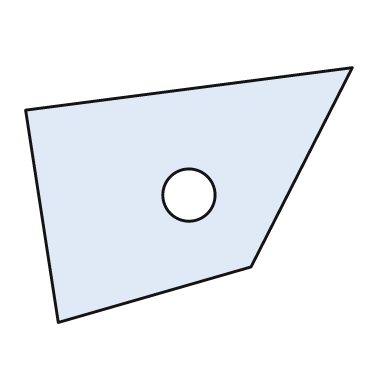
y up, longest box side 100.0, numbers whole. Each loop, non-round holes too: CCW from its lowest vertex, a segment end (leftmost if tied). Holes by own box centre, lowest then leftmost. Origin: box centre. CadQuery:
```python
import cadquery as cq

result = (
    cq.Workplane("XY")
    .moveTo(-40.0, -39.0)
    .lineTo(19.0, -22.0)
    .lineTo(50.0, 39.0)
    .lineTo(-50.0, 26.0)
    .close()
    .moveTo(0.0, 0.0)
    .circle(8.0)
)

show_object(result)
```